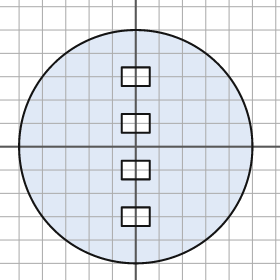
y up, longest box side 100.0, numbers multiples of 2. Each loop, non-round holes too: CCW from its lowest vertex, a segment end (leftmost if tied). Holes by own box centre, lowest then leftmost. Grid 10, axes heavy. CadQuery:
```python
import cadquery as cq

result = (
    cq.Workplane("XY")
    .moveTo(0.0, 0.0)
    .circle(50.0)
    .moveTo(-6.0, -34.0)
    .lineTo(6.0, -34.0)
    .lineTo(6.0, -26.0)
    .lineTo(-6.0, -26.0)
    .close()
    .moveTo(-6.0, -14.0)
    .lineTo(6.0, -14.0)
    .lineTo(6.0, -6.0)
    .lineTo(-6.0, -6.0)
    .close()
    .moveTo(-6.0, 6.0)
    .lineTo(6.0, 6.0)
    .lineTo(6.0, 14.0)
    .lineTo(-6.0, 14.0)
    .close()
    .moveTo(-6.0, 26.0)
    .lineTo(6.0, 26.0)
    .lineTo(6.0, 34.0)
    .lineTo(-6.0, 34.0)
    .close()
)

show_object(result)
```